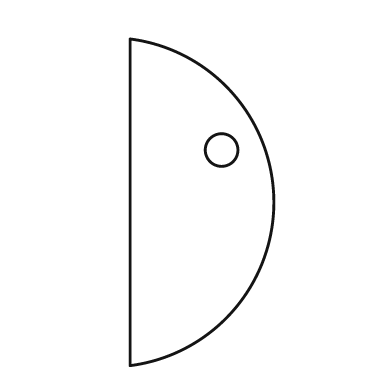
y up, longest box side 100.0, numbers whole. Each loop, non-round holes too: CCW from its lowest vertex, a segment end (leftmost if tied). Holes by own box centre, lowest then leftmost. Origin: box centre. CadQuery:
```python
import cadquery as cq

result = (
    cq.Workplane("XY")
    .moveTo(-22.0, -50.0)
    .threePointArc((22.0, 0.0), (-22.0, 50.0))
    .close()
    .moveTo(6.0, 16.0)
    .circle(5.0)
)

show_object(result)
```